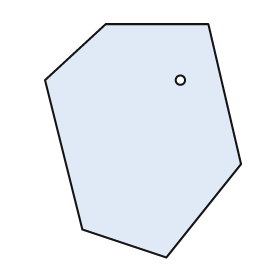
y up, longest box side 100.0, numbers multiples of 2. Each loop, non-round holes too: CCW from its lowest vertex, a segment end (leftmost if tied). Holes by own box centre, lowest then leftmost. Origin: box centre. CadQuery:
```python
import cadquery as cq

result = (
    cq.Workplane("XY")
    .moveTo(10.0, -50.0)
    .lineTo(42.0, -10.0)
    .lineTo(28.0, 50.0)
    .lineTo(-16.0, 50.0)
    .lineTo(-42.0, 26.0)
    .lineTo(-26.0, -38.0)
    .close()
    .moveTo(16.0, 26.0)
    .circle(2.0)
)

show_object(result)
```